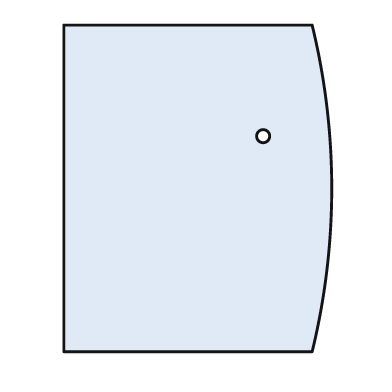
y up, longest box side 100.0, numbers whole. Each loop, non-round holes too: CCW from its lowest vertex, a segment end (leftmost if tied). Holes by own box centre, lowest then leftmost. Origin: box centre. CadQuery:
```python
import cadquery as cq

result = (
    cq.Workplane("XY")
    .moveTo(-41.0, -50.0)
    .lineTo(35.0, -50.0)
    .threePointArc((41.0, 0.0), (35.0, 50.0))
    .lineTo(-41.0, 50.0)
    .close()
    .moveTo(20.0, 16.0)
    .circle(2.0)
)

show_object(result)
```